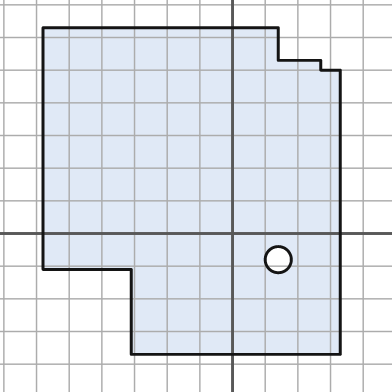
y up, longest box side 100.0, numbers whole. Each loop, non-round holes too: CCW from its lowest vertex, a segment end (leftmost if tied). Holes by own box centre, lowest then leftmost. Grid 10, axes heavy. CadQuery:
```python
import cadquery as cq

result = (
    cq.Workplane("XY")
    .moveTo(-31.0, -37.0)
    .lineTo(33.0, -37.0)
    .lineTo(33.0, 50.0)
    .lineTo(27.0, 50.0)
    .lineTo(27.0, 53.0)
    .lineTo(14.0, 53.0)
    .lineTo(14.0, 63.0)
    .lineTo(-58.0, 63.0)
    .lineTo(-58.0, -11.0)
    .lineTo(-31.0, -11.0)
    .close()
    .moveTo(14.0, -8.0)
    .circle(4.0)
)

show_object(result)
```